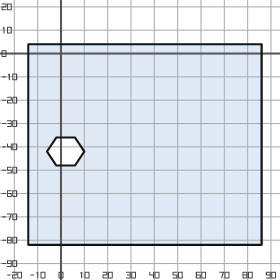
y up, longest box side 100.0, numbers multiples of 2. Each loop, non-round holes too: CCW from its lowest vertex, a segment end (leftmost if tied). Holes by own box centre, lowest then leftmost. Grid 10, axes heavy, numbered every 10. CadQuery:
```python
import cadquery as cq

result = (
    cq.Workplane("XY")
    .moveTo(-14.0, -82.0)
    .lineTo(86.0, -82.0)
    .lineTo(86.0, 4.0)
    .lineTo(-14.0, 4.0)
    .close()
    .moveTo(-2.0, -48.0)
    .lineTo(6.0, -48.0)
    .lineTo(10.0, -42.0)
    .lineTo(6.0, -36.0)
    .lineTo(-2.0, -36.0)
    .lineTo(-6.0, -42.0)
    .close()
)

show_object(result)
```